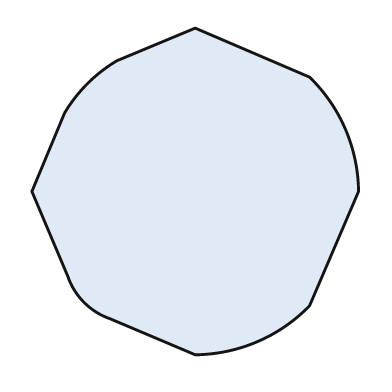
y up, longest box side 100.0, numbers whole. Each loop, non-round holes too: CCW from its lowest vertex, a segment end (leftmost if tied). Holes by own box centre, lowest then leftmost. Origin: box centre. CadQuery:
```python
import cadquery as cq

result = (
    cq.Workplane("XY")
    .moveTo(0.0, -50.0)
    .threePointArc((19.0, -46.0), (35.0, -35.0))
    .lineTo(50.0, 0.0)
    .threePointArc((46.0, 19.0), (35.0, 35.0))
    .lineTo(0.0, 50.0)
    .lineTo(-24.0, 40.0)
    .threePointArc((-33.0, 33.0), (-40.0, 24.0))
    .lineTo(-50.0, 0.0)
    .lineTo(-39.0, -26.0)
    .threePointArc((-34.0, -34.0), (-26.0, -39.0))
    .close()
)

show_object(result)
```